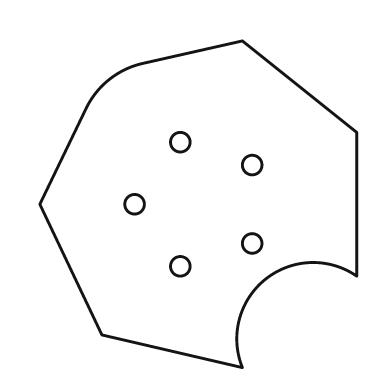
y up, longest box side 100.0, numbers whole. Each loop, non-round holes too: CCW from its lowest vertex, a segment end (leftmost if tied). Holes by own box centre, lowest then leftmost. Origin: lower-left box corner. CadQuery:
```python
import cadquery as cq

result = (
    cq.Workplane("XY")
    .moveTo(62.0, 0.0)
    .threePointArc((69.0, 27.0), (97.0, 28.0))
    .lineTo(97.0, 72.0)
    .lineTo(62.0, 100.0)
    .lineTo(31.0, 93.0)
    .threePointArc((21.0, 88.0), (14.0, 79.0))
    .lineTo(0.0, 50.0)
    .lineTo(19.0, 10.0)
    .close()
    .moveTo(43.0, 31.0)
    .circle(3.0)
    .moveTo(65.0, 38.0)
    .circle(3.0)
    .moveTo(29.0, 50.0)
    .circle(3.0)
    .moveTo(65.0, 62.0)
    .circle(3.0)
    .moveTo(43.0, 69.0)
    .circle(3.0)
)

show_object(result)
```